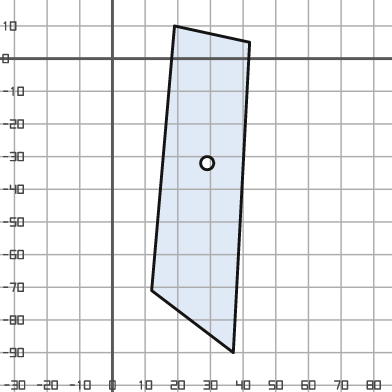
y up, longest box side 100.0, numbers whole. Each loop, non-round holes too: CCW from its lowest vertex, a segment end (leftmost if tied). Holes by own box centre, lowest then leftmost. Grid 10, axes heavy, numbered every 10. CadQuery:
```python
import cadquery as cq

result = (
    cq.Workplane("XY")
    .moveTo(37.0, -90.0)
    .lineTo(42.0, 5.0)
    .lineTo(19.0, 10.0)
    .lineTo(12.0, -71.0)
    .close()
    .moveTo(29.0, -32.0)
    .circle(2.0)
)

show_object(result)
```